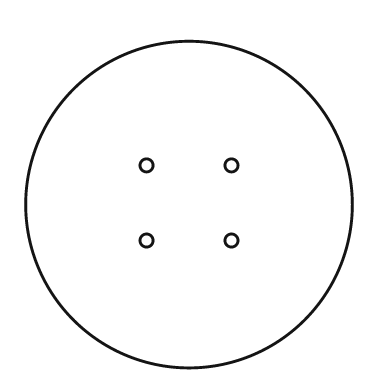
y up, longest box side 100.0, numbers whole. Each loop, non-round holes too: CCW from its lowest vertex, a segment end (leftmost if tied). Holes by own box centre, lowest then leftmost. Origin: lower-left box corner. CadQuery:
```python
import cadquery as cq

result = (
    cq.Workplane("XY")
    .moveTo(50.0, 50.0)
    .circle(50.0)
    .moveTo(37.0, 39.0)
    .circle(2.0)
    .moveTo(63.0, 39.0)
    .circle(2.0)
    .moveTo(37.0, 62.0)
    .circle(2.0)
    .moveTo(63.0, 62.0)
    .circle(2.0)
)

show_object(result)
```